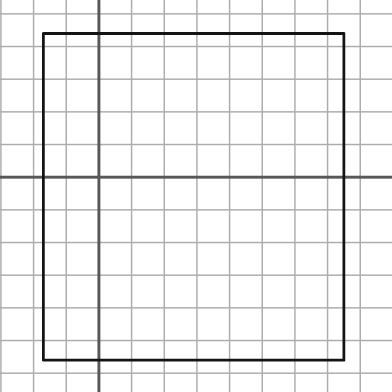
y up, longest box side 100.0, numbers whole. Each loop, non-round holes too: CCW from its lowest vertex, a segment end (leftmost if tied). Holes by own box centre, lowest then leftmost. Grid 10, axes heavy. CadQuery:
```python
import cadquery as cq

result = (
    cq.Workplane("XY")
    .moveTo(-17.0, -56.0)
    .lineTo(75.0, -56.0)
    .lineTo(75.0, 44.0)
    .lineTo(-17.0, 44.0)
    .close()
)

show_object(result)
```